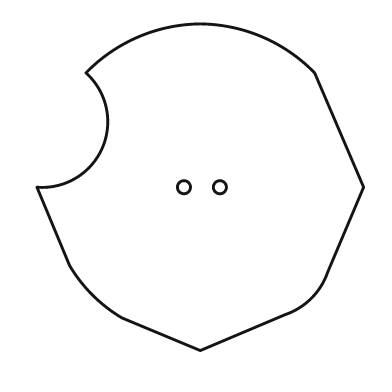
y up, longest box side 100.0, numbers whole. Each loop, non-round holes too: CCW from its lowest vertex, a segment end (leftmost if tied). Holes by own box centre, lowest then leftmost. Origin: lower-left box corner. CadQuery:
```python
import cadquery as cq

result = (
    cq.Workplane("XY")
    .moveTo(50.0, 0.0)
    .lineTo(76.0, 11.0)
    .threePointArc((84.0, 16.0), (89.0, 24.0))
    .lineTo(100.0, 50.0)
    .lineTo(85.0, 85.0)
    .threePointArc((69.0, 96.0), (50.0, 100.0))
    .threePointArc((31.0, 96.0), (15.0, 85.0))
    .threePointArc((20.0, 62.0), (0.0, 50.0))
    .lineTo(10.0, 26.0)
    .threePointArc((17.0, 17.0), (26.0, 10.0))
    .close()
    .moveTo(45.0, 50.0)
    .circle(2.0)
    .moveTo(56.0, 50.0)
    .circle(2.0)
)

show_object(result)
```